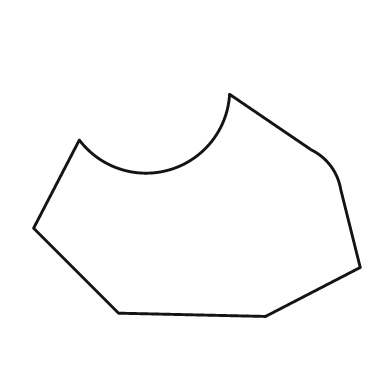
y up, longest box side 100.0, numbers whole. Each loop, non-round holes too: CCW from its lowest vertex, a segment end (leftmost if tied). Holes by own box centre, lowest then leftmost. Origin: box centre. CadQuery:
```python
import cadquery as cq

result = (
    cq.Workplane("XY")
    .moveTo(21.0, -34.0)
    .lineTo(50.0, -19.0)
    .lineTo(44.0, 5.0)
    .threePointArc((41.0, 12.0), (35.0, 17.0))
    .lineTo(10.0, 34.0)
    .threePointArc((-8.0, 11.0), (-36.0, 20.0))
    .lineTo(-50.0, -7.0)
    .lineTo(-24.0, -33.0)
    .close()
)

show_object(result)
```